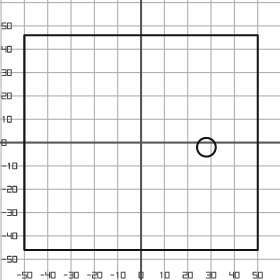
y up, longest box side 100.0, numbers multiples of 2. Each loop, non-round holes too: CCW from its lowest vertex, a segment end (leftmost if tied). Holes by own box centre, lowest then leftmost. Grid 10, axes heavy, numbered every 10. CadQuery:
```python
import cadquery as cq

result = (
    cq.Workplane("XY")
    .moveTo(-50.0, -46.0)
    .lineTo(50.0, -46.0)
    .lineTo(50.0, 46.0)
    .lineTo(-50.0, 46.0)
    .close()
    .moveTo(28.0, -2.0)
    .circle(4.0)
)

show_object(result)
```